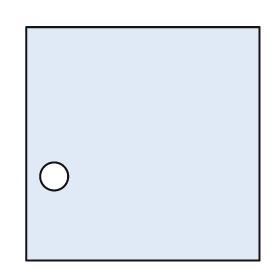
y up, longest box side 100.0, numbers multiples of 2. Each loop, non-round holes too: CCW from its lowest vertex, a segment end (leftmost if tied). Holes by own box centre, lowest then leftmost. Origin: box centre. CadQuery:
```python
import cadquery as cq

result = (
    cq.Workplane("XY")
    .moveTo(-50.0, -50.0)
    .lineTo(50.0, -50.0)
    .lineTo(50.0, 50.0)
    .lineTo(-50.0, 50.0)
    .close()
    .moveTo(-38.0, -14.0)
    .circle(6.0)
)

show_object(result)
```